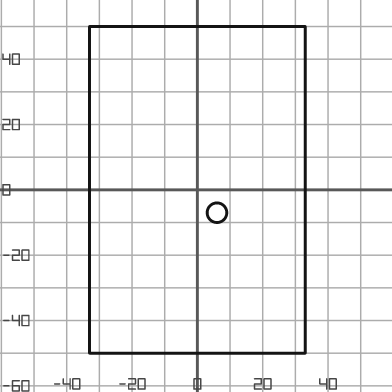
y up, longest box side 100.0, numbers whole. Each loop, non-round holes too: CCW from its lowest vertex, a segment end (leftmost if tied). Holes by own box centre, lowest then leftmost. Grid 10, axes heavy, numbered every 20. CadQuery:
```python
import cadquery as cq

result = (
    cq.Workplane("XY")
    .moveTo(-33.0, -50.0)
    .lineTo(33.0, -50.0)
    .lineTo(33.0, 50.0)
    .lineTo(-33.0, 50.0)
    .close()
    .moveTo(6.0, -7.0)
    .circle(3.0)
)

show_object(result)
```